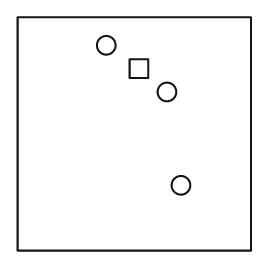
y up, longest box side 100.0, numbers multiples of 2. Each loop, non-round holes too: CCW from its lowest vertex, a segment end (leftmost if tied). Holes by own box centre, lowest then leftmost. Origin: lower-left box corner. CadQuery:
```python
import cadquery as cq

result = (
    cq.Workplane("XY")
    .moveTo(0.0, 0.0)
    .lineTo(100.0, 0.0)
    .lineTo(100.0, 100.0)
    .lineTo(0.0, 100.0)
    .close()
    .moveTo(70.0, 28.0)
    .circle(4.0)
    .moveTo(64.0, 68.0)
    .circle(4.0)
    .moveTo(48.0, 74.0)
    .lineTo(56.0, 74.0)
    .lineTo(56.0, 82.0)
    .lineTo(48.0, 82.0)
    .close()
    .moveTo(38.0, 88.0)
    .circle(4.0)
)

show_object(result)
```